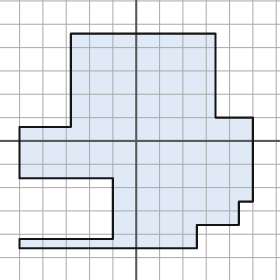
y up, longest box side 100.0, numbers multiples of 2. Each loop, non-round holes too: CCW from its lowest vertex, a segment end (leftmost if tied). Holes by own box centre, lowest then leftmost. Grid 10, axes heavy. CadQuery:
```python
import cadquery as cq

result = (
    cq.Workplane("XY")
    .moveTo(-50.0, -46.0)
    .lineTo(26.0, -46.0)
    .lineTo(26.0, -36.0)
    .lineTo(44.0, -36.0)
    .lineTo(44.0, -26.0)
    .lineTo(50.0, -26.0)
    .lineTo(50.0, 10.0)
    .lineTo(34.0, 10.0)
    .lineTo(34.0, 46.0)
    .lineTo(-28.0, 46.0)
    .lineTo(-28.0, 6.0)
    .lineTo(-50.0, 6.0)
    .lineTo(-50.0, -16.0)
    .lineTo(-10.0, -16.0)
    .lineTo(-10.0, -42.0)
    .lineTo(-50.0, -42.0)
    .close()
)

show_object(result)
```